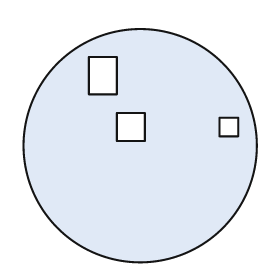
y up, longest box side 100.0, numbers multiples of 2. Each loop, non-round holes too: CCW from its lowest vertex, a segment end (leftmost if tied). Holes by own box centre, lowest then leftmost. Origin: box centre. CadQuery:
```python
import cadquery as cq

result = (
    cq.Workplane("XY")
    .moveTo(0.0, 0.0)
    .circle(50.0)
    .moveTo(-10.0, 2.0)
    .lineTo(2.0, 2.0)
    .lineTo(2.0, 14.0)
    .lineTo(-10.0, 14.0)
    .close()
    .moveTo(34.0, 4.0)
    .lineTo(42.0, 4.0)
    .lineTo(42.0, 12.0)
    .lineTo(34.0, 12.0)
    .close()
    .moveTo(-22.0, 22.0)
    .lineTo(-10.0, 22.0)
    .lineTo(-10.0, 38.0)
    .lineTo(-22.0, 38.0)
    .close()
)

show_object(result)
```